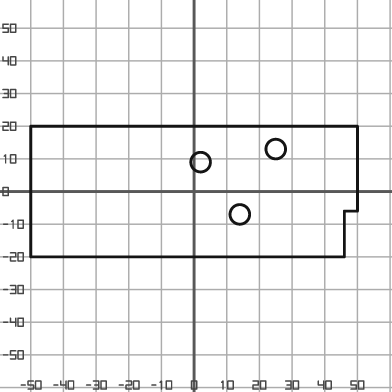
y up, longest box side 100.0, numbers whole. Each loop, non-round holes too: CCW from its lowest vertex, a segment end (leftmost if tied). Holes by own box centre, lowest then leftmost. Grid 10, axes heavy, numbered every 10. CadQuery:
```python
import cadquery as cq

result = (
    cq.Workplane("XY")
    .moveTo(-50.0, -20.0)
    .lineTo(46.0, -20.0)
    .lineTo(46.0, -6.0)
    .lineTo(50.0, -6.0)
    .lineTo(50.0, 20.0)
    .lineTo(-50.0, 20.0)
    .close()
    .moveTo(14.0, -7.0)
    .circle(3.0)
    .moveTo(2.0, 9.0)
    .circle(3.0)
    .moveTo(25.0, 13.0)
    .circle(3.0)
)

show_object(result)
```